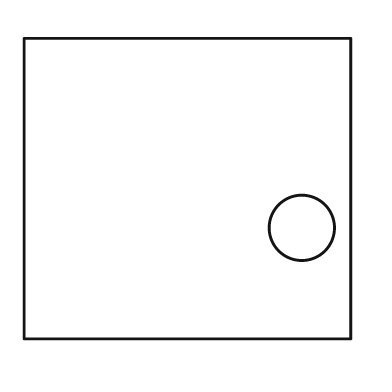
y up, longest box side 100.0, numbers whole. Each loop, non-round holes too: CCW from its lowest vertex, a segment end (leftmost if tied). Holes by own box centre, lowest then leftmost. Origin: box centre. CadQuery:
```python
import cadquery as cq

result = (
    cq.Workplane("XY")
    .moveTo(-50.0, -46.0)
    .lineTo(50.0, -46.0)
    .lineTo(50.0, 46.0)
    .lineTo(-50.0, 46.0)
    .close()
    .moveTo(35.0, -12.0)
    .circle(10.0)
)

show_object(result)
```